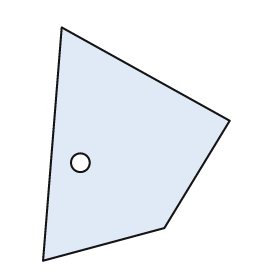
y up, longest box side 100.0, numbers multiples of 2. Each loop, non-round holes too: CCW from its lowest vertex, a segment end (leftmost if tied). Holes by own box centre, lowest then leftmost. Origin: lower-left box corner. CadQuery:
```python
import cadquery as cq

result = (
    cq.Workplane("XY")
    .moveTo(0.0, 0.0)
    .lineTo(52.0, 14.0)
    .lineTo(80.0, 60.0)
    .lineTo(8.0, 100.0)
    .close()
    .moveTo(16.0, 42.0)
    .circle(4.0)
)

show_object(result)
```